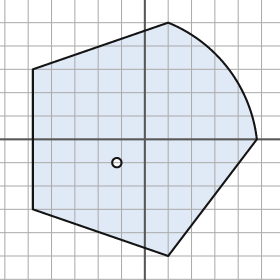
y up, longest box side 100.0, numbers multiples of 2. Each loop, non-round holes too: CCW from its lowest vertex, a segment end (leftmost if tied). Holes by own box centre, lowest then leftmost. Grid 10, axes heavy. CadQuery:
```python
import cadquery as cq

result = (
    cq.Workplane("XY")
    .moveTo(10.0, -50.0)
    .lineTo(48.0, 0.0)
    .threePointArc((36.0, 30.0), (10.0, 50.0))
    .lineTo(-48.0, 30.0)
    .lineTo(-48.0, -30.0)
    .close()
    .moveTo(-12.0, -10.0)
    .circle(2.0)
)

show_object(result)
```